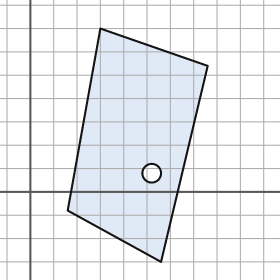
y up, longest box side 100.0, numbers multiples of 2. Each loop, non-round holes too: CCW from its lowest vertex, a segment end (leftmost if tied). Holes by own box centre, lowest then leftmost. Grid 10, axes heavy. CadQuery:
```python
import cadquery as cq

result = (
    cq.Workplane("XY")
    .moveTo(56.0, -30.0)
    .lineTo(76.0, 54.0)
    .lineTo(30.0, 70.0)
    .lineTo(16.0, -8.0)
    .close()
    .moveTo(52.0, 8.0)
    .circle(4.0)
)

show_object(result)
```